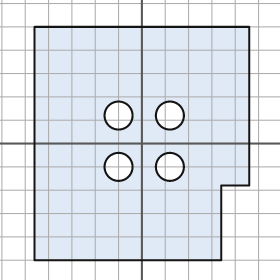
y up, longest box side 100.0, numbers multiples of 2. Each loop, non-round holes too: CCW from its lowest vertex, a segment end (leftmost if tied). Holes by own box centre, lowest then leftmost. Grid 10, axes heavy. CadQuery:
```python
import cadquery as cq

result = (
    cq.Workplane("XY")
    .moveTo(-46.0, -50.0)
    .lineTo(34.0, -50.0)
    .lineTo(34.0, -18.0)
    .lineTo(46.0, -18.0)
    .lineTo(46.0, 50.0)
    .lineTo(-46.0, 50.0)
    .close()
    .moveTo(-10.0, -10.0)
    .circle(6.0)
    .moveTo(12.0, -10.0)
    .circle(6.0)
    .moveTo(-10.0, 12.0)
    .circle(6.0)
    .moveTo(12.0, 12.0)
    .circle(6.0)
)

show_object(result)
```